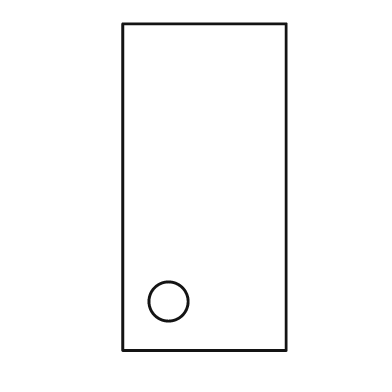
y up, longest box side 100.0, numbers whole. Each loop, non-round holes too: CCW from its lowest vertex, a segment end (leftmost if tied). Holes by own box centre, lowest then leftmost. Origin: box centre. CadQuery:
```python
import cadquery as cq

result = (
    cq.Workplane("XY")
    .moveTo(-25.0, -50.0)
    .lineTo(25.0, -50.0)
    .lineTo(25.0, 50.0)
    .lineTo(-25.0, 50.0)
    .close()
    .moveTo(-11.0, -35.0)
    .circle(6.0)
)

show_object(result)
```